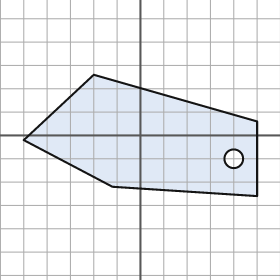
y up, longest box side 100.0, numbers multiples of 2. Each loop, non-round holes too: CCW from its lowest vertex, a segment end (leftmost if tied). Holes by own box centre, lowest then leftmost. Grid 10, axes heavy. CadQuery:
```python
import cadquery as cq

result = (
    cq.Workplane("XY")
    .moveTo(50.0, -26.0)
    .lineTo(50.0, 6.0)
    .lineTo(-20.0, 26.0)
    .lineTo(-50.0, -2.0)
    .lineTo(-12.0, -22.0)
    .close()
    .moveTo(40.0, -10.0)
    .circle(4.0)
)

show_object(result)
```